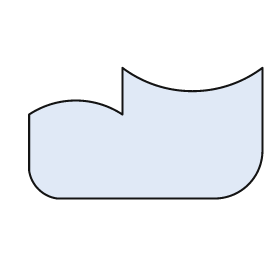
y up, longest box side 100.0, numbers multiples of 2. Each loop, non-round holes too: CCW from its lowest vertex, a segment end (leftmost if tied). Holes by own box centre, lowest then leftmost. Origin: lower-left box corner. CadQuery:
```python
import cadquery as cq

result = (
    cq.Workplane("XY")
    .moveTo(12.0, 0.0)
    .lineTo(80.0, 0.0)
    .threePointArc((94.0, 6.0), (100.0, 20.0))
    .lineTo(100.0, 56.0)
    .threePointArc((70.0, 46.0), (40.0, 56.0))
    .lineTo(40.0, 36.0)
    .threePointArc((20.0, 42.0), (0.0, 36.0))
    .lineTo(0.0, 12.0)
    .threePointArc((4.0, 4.0), (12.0, 0.0))
    .close()
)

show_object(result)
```